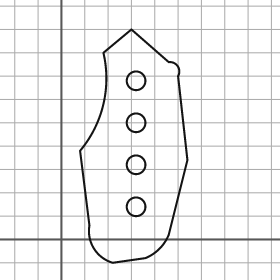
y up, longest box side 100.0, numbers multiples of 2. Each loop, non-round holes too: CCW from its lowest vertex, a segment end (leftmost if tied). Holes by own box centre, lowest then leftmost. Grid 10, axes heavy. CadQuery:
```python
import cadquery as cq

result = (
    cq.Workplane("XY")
    .moveTo(22.0, -10.0)
    .lineTo(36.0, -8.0)
    .threePointArc((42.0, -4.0), (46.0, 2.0))
    .lineTo(54.0, 34.0)
    .lineTo(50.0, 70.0)
    .threePointArc((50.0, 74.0), (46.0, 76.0))
    .lineTo(30.0, 90.0)
    .lineTo(18.0, 80.0)
    .threePointArc((18.0, 58.0), (8.0, 38.0))
    .lineTo(12.0, 6.0)
    .threePointArc((14.0, -4.0), (22.0, -10.0))
    .close()
    .moveTo(32.0, 14.0)
    .circle(4.0)
    .moveTo(32.0, 32.0)
    .circle(4.0)
    .moveTo(32.0, 50.0)
    .circle(4.0)
    .moveTo(32.0, 68.0)
    .circle(4.0)
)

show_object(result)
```